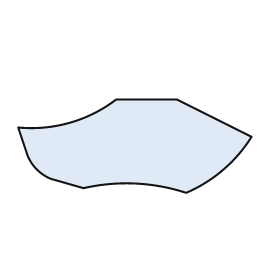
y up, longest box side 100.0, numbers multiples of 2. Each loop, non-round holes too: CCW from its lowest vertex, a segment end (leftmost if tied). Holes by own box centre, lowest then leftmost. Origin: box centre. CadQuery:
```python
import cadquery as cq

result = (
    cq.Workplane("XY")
    .moveTo(22.0, -20.0)
    .threePointArc((38.0, -10.0), (50.0, 4.0))
    .lineTo(18.0, 20.0)
    .lineTo(-8.0, 20.0)
    .threePointArc((-28.0, 10.0), (-50.0, 8.0))
    .lineTo(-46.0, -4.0)
    .threePointArc((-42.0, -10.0), (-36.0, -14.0))
    .lineTo(-22.0, -18.0)
    .threePointArc((0.0, -16.0), (22.0, -20.0))
    .close()
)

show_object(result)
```